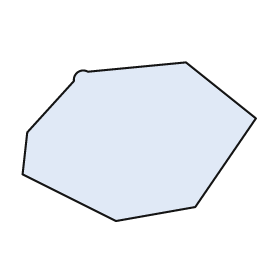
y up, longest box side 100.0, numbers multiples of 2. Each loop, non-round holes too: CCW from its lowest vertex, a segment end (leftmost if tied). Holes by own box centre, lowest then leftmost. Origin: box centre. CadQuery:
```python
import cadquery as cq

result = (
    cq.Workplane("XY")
    .moveTo(-10.0, -34.0)
    .lineTo(24.0, -28.0)
    .lineTo(50.0, 10.0)
    .lineTo(20.0, 34.0)
    .lineTo(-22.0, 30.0)
    .threePointArc((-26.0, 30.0), (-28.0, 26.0))
    .lineTo(-48.0, 4.0)
    .lineTo(-50.0, -14.0)
    .close()
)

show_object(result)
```